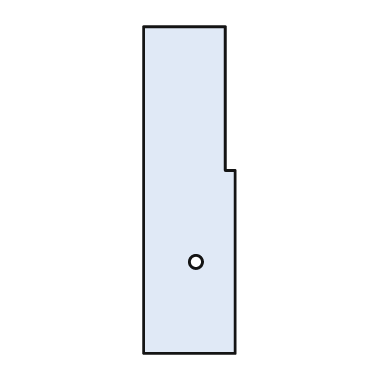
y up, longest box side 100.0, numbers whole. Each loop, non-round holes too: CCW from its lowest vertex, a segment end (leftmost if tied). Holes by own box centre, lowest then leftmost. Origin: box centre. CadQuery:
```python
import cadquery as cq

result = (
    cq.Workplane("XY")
    .moveTo(-14.0, -50.0)
    .lineTo(14.0, -50.0)
    .lineTo(14.0, 6.0)
    .lineTo(11.0, 6.0)
    .lineTo(11.0, 50.0)
    .lineTo(-14.0, 50.0)
    .close()
    .moveTo(2.0, -22.0)
    .circle(2.0)
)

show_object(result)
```